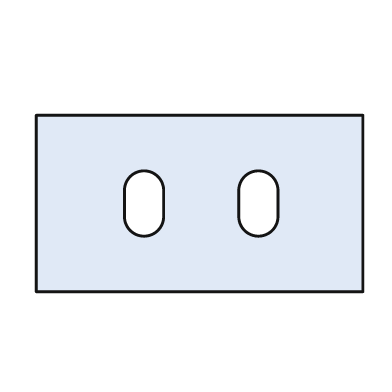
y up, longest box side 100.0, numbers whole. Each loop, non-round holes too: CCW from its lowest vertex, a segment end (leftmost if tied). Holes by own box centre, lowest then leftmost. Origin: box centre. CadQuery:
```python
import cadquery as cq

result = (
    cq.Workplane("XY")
    .moveTo(-50.0, -27.0)
    .lineTo(50.0, -27.0)
    .lineTo(50.0, 27.0)
    .lineTo(-50.0, 27.0)
    .close()
    .moveTo(-23.0, -4.0)
    .threePointArc((-17.0, -10.0), (-11.0, -4.0))
    .lineTo(-11.0, 4.0)
    .threePointArc((-17.0, 10.0), (-23.0, 4.0))
    .close()
    .moveTo(12.0, -4.0)
    .threePointArc((18.0, -10.0), (24.0, -4.0))
    .lineTo(24.0, 4.0)
    .threePointArc((18.0, 10.0), (12.0, 4.0))
    .close()
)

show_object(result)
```